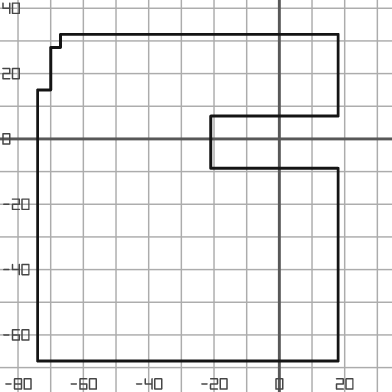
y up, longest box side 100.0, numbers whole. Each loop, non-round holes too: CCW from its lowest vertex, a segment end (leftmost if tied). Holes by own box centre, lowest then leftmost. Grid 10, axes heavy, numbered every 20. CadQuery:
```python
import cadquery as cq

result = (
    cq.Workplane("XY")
    .moveTo(-74.0, -68.0)
    .lineTo(18.0, -68.0)
    .lineTo(18.0, -9.0)
    .lineTo(-21.0, -9.0)
    .lineTo(-21.0, 7.0)
    .lineTo(18.0, 7.0)
    .lineTo(18.0, 32.0)
    .lineTo(-67.0, 32.0)
    .lineTo(-67.0, 28.0)
    .lineTo(-70.0, 28.0)
    .lineTo(-70.0, 15.0)
    .lineTo(-74.0, 15.0)
    .close()
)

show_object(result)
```